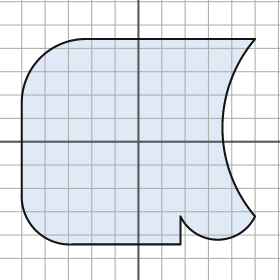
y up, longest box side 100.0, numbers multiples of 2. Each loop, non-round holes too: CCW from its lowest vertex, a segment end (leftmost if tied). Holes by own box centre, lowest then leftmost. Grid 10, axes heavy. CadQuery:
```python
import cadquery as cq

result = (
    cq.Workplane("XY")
    .moveTo(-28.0, -44.0)
    .lineTo(18.0, -44.0)
    .lineTo(18.0, -32.0)
    .threePointArc((34.0, -42.0), (50.0, -32.0))
    .threePointArc((36.0, 6.0), (50.0, 44.0))
    .lineTo(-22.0, 44.0)
    .threePointArc((-42.0, 36.0), (-50.0, 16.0))
    .lineTo(-50.0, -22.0)
    .threePointArc((-44.0, -38.0), (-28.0, -44.0))
    .close()
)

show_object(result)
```